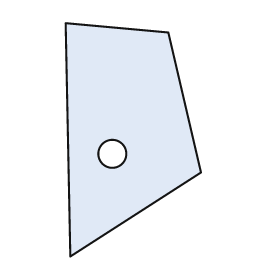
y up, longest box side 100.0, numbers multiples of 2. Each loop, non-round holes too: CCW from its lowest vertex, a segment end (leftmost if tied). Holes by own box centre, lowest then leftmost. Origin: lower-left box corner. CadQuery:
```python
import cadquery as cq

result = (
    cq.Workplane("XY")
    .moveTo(2.0, 0.0)
    .lineTo(58.0, 36.0)
    .lineTo(44.0, 96.0)
    .lineTo(0.0, 100.0)
    .close()
    .moveTo(20.0, 44.0)
    .circle(6.0)
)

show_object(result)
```